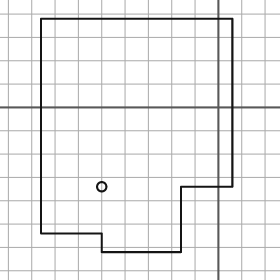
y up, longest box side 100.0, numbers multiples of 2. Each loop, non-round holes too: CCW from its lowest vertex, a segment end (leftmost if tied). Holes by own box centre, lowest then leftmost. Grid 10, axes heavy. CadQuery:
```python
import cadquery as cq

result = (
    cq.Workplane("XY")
    .moveTo(-50.0, -62.0)
    .lineTo(-16.0, -62.0)
    .lineTo(-16.0, -34.0)
    .lineTo(6.0, -34.0)
    .lineTo(6.0, 38.0)
    .lineTo(-76.0, 38.0)
    .lineTo(-76.0, -54.0)
    .lineTo(-50.0, -54.0)
    .close()
    .moveTo(-50.0, -34.0)
    .circle(2.0)
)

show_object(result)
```